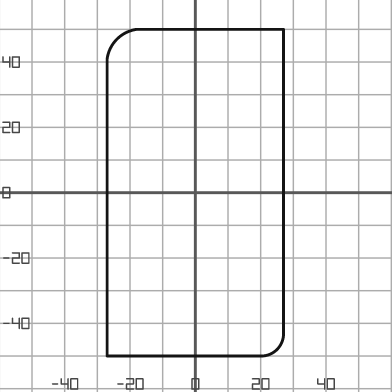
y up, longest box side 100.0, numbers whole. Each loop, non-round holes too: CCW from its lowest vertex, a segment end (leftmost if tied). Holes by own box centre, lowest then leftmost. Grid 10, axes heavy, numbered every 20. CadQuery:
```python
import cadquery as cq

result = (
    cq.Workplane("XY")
    .moveTo(-27.0, -50.0)
    .lineTo(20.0, -50.0)
    .threePointArc((25.0, -48.0), (27.0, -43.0))
    .lineTo(27.0, 50.0)
    .lineTo(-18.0, 50.0)
    .threePointArc((-24.0, 47.0), (-27.0, 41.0))
    .close()
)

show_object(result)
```